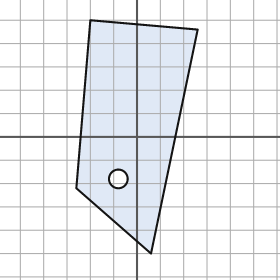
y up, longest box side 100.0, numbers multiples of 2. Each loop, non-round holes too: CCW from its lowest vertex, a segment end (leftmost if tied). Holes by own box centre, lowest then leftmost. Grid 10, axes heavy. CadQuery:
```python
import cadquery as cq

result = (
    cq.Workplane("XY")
    .moveTo(6.0, -50.0)
    .lineTo(26.0, 46.0)
    .lineTo(-20.0, 50.0)
    .lineTo(-26.0, -22.0)
    .close()
    .moveTo(-8.0, -18.0)
    .circle(4.0)
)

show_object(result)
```